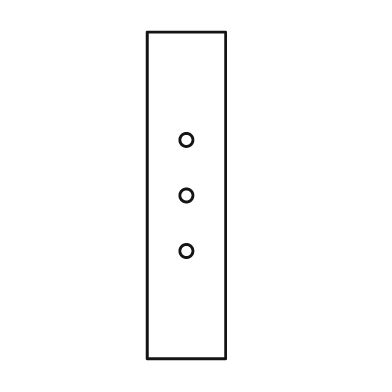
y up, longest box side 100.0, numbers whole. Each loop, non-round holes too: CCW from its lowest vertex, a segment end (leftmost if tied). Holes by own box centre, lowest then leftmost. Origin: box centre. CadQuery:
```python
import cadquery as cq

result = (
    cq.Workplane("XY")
    .moveTo(-12.0, -50.0)
    .lineTo(12.0, -50.0)
    .lineTo(12.0, 50.0)
    .lineTo(-12.0, 50.0)
    .close()
    .moveTo(0.0, -17.0)
    .circle(2.0)
    .moveTo(0.0, 0.0)
    .circle(2.0)
    .moveTo(0.0, 17.0)
    .circle(2.0)
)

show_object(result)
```